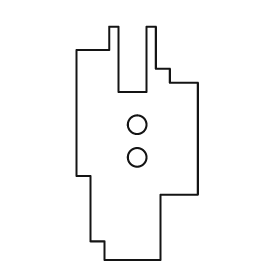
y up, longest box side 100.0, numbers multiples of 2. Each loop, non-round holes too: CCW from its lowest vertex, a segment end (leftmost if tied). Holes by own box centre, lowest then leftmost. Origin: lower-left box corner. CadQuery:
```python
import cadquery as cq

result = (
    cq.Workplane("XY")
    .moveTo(12.0, 0.0)
    .lineTo(36.0, 0.0)
    .lineTo(36.0, 28.0)
    .lineTo(52.0, 28.0)
    .lineTo(52.0, 76.0)
    .lineTo(40.0, 76.0)
    .lineTo(40.0, 82.0)
    .lineTo(34.0, 82.0)
    .lineTo(34.0, 100.0)
    .lineTo(30.0, 100.0)
    .lineTo(30.0, 72.0)
    .lineTo(18.0, 72.0)
    .lineTo(18.0, 100.0)
    .lineTo(14.0, 100.0)
    .lineTo(14.0, 90.0)
    .lineTo(0.0, 90.0)
    .lineTo(0.0, 36.0)
    .lineTo(6.0, 36.0)
    .lineTo(6.0, 8.0)
    .lineTo(12.0, 8.0)
    .close()
    .moveTo(26.0, 44.0)
    .circle(4.0)
    .moveTo(26.0, 58.0)
    .circle(4.0)
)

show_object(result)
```